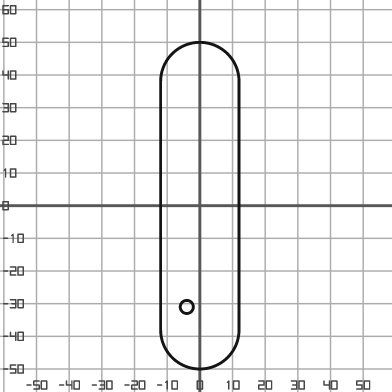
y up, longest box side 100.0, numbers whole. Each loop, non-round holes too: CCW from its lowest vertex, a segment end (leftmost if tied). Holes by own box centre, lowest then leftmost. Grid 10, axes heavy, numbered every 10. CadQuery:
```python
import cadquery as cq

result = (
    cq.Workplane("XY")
    .moveTo(-12.0, -38.0)
    .threePointArc((0.0, -50.0), (12.0, -38.0))
    .lineTo(12.0, 38.0)
    .threePointArc((0.0, 50.0), (-12.0, 38.0))
    .close()
    .moveTo(-4.0, -31.0)
    .circle(2.0)
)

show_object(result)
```